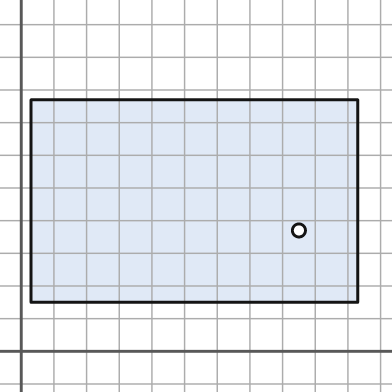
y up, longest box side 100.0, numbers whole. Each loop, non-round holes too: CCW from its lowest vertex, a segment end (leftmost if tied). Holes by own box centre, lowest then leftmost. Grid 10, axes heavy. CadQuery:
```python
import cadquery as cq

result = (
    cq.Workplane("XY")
    .moveTo(3.0, 15.0)
    .lineTo(103.0, 15.0)
    .lineTo(103.0, 77.0)
    .lineTo(3.0, 77.0)
    .close()
    .moveTo(85.0, 37.0)
    .circle(2.0)
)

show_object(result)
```